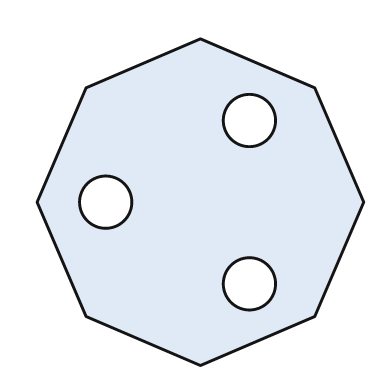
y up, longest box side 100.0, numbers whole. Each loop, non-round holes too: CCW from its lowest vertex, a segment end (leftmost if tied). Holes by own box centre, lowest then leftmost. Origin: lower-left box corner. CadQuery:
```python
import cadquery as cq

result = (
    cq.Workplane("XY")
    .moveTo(50.0, 0.0)
    .lineTo(85.0, 15.0)
    .lineTo(100.0, 50.0)
    .lineTo(85.0, 85.0)
    .lineTo(50.0, 100.0)
    .lineTo(15.0, 85.0)
    .lineTo(0.0, 50.0)
    .lineTo(15.0, 15.0)
    .close()
    .moveTo(65.0, 25.0)
    .circle(8.0)
    .moveTo(21.0, 50.0)
    .circle(8.0)
    .moveTo(65.0, 75.0)
    .circle(8.0)
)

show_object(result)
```